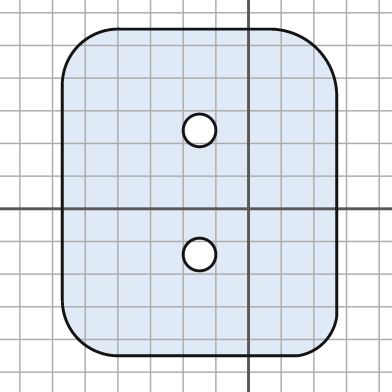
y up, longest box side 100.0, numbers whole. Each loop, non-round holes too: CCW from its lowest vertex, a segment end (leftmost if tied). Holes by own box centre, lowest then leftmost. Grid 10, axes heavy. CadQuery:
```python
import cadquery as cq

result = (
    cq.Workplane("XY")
    .moveTo(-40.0, -45.0)
    .lineTo(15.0, -45.0)
    .threePointArc((23.0, -41.0), (27.0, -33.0))
    .lineTo(27.0, 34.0)
    .threePointArc((21.0, 49.0), (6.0, 55.0))
    .lineTo(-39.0, 55.0)
    .threePointArc((-52.0, 50.0), (-57.0, 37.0))
    .lineTo(-57.0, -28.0)
    .threePointArc((-52.0, -40.0), (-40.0, -45.0))
    .close()
    .moveTo(-15.0, -14.0)
    .circle(5.0)
    .moveTo(-15.0, 24.0)
    .circle(5.0)
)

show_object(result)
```